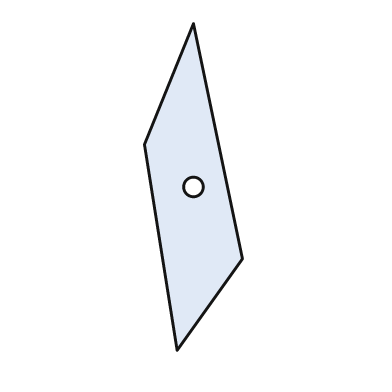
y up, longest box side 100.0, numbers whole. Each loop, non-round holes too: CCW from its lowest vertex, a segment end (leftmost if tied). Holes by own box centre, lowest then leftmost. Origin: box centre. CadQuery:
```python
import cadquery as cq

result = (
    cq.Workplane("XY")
    .moveTo(-5.0, -50.0)
    .lineTo(15.0, -22.0)
    .lineTo(0.0, 50.0)
    .lineTo(-15.0, 13.0)
    .close()
    .moveTo(0.0, 0.0)
    .circle(3.0)
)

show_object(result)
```